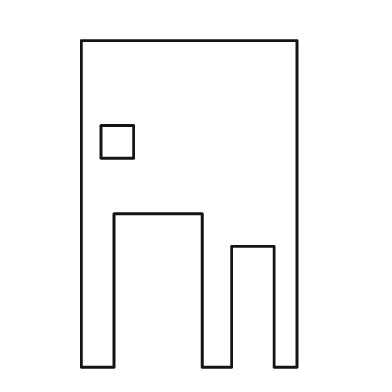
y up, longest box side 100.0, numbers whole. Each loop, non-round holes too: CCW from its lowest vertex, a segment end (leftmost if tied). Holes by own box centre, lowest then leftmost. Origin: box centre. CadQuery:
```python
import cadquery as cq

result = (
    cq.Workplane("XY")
    .moveTo(-33.0, -50.0)
    .lineTo(-23.0, -50.0)
    .lineTo(-23.0, -3.0)
    .lineTo(4.0, -3.0)
    .lineTo(4.0, -50.0)
    .lineTo(13.0, -50.0)
    .lineTo(13.0, -13.0)
    .lineTo(26.0, -13.0)
    .lineTo(26.0, -50.0)
    .lineTo(33.0, -50.0)
    .lineTo(33.0, 50.0)
    .lineTo(-33.0, 50.0)
    .close()
    .moveTo(-27.0, 14.0)
    .lineTo(-17.0, 14.0)
    .lineTo(-17.0, 24.0)
    .lineTo(-27.0, 24.0)
    .close()
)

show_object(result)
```